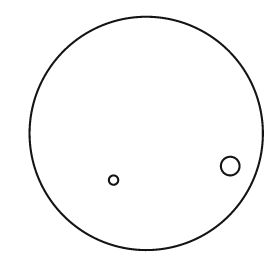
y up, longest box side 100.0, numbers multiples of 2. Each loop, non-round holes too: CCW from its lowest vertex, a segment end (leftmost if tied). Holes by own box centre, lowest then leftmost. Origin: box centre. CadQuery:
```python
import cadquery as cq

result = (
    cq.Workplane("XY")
    .moveTo(0.0, 0.0)
    .circle(50.0)
    .moveTo(-14.0, -20.0)
    .circle(2.0)
    .moveTo(36.0, -14.0)
    .circle(4.0)
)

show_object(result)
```